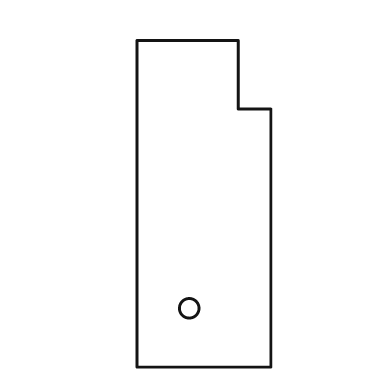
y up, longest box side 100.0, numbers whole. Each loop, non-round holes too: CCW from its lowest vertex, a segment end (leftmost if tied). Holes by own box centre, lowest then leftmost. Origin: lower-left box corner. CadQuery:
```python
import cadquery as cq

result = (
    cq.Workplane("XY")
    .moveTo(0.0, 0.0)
    .lineTo(41.0, 0.0)
    .lineTo(41.0, 79.0)
    .lineTo(31.0, 79.0)
    .lineTo(31.0, 100.0)
    .lineTo(0.0, 100.0)
    .close()
    .moveTo(16.0, 18.0)
    .circle(3.0)
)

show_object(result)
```